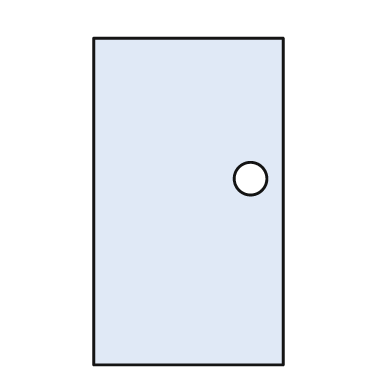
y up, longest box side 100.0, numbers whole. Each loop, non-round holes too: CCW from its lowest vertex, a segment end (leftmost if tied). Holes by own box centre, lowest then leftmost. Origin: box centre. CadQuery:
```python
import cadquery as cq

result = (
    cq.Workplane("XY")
    .moveTo(-29.0, -50.0)
    .lineTo(29.0, -50.0)
    .lineTo(29.0, 50.0)
    .lineTo(-29.0, 50.0)
    .close()
    .moveTo(19.0, 7.0)
    .circle(5.0)
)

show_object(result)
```